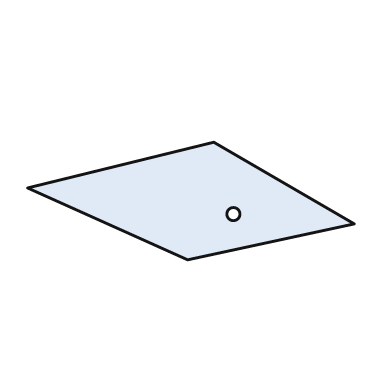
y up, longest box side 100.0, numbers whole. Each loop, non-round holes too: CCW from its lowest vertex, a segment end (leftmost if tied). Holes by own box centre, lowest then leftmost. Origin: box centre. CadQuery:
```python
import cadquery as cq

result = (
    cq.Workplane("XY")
    .moveTo(-1.0, -18.0)
    .lineTo(50.0, -7.0)
    .lineTo(7.0, 18.0)
    .lineTo(-50.0, 4.0)
    .close()
    .moveTo(13.0, -4.0)
    .circle(2.0)
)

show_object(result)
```